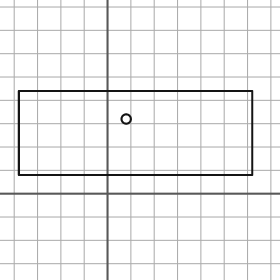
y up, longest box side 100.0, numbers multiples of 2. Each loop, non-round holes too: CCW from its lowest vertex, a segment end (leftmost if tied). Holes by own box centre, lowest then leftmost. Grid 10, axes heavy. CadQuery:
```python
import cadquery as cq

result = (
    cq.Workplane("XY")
    .moveTo(-38.0, 8.0)
    .lineTo(62.0, 8.0)
    .lineTo(62.0, 44.0)
    .lineTo(-38.0, 44.0)
    .close()
    .moveTo(8.0, 32.0)
    .circle(2.0)
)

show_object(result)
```